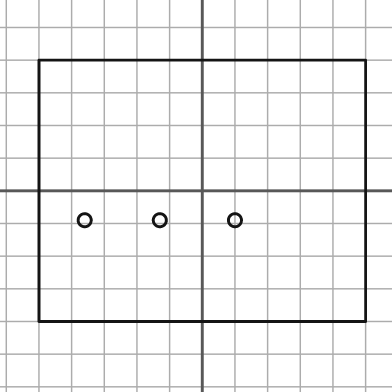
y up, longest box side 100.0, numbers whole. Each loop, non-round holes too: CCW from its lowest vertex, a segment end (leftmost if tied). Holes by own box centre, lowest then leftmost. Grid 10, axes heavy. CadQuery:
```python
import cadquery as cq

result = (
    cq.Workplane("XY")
    .moveTo(-50.0, -40.0)
    .lineTo(50.0, -40.0)
    .lineTo(50.0, 40.0)
    .lineTo(-50.0, 40.0)
    .close()
    .moveTo(-36.0, -9.0)
    .circle(2.0)
    .moveTo(-13.0, -9.0)
    .circle(2.0)
    .moveTo(10.0, -9.0)
    .circle(2.0)
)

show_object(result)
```